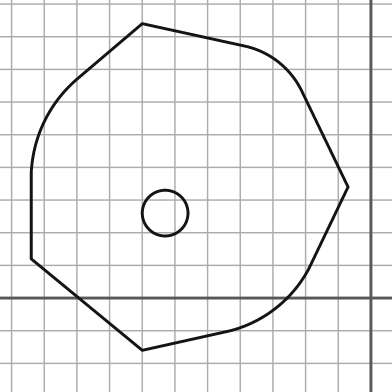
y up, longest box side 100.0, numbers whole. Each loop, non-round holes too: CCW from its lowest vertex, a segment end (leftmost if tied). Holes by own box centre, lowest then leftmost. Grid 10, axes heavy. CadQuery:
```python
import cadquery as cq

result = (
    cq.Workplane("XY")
    .moveTo(-70.0, -16.0)
    .lineTo(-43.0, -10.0)
    .threePointArc((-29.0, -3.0), (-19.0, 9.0))
    .lineTo(-7.0, 34.0)
    .lineTo(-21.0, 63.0)
    .threePointArc((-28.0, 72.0), (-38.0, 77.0))
    .lineTo(-70.0, 84.0)
    .lineTo(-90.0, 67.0)
    .threePointArc((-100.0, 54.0), (-104.0, 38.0))
    .lineTo(-104.0, 12.0)
    .close()
    .moveTo(-63.0, 26.0)
    .circle(7.0)
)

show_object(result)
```